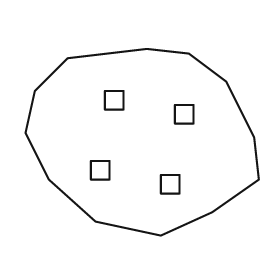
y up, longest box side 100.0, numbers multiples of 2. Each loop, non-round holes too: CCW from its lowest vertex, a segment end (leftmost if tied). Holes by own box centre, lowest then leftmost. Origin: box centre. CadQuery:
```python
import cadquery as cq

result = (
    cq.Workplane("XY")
    .moveTo(8.0, -40.0)
    .lineTo(30.0, -30.0)
    .lineTo(50.0, -16.0)
    .lineTo(48.0, 2.0)
    .lineTo(36.0, 26.0)
    .lineTo(20.0, 38.0)
    .lineTo(2.0, 40.0)
    .lineTo(-32.0, 36.0)
    .lineTo(-46.0, 22.0)
    .lineTo(-50.0, 4.0)
    .lineTo(-40.0, -16.0)
    .lineTo(-20.0, -34.0)
    .close()
    .moveTo(8.0, -22.0)
    .lineTo(16.0, -22.0)
    .lineTo(16.0, -14.0)
    .lineTo(8.0, -14.0)
    .close()
    .moveTo(-22.0, -16.0)
    .lineTo(-14.0, -16.0)
    .lineTo(-14.0, -8.0)
    .lineTo(-22.0, -8.0)
    .close()
    .moveTo(14.0, 8.0)
    .lineTo(22.0, 8.0)
    .lineTo(22.0, 16.0)
    .lineTo(14.0, 16.0)
    .close()
    .moveTo(-16.0, 14.0)
    .lineTo(-8.0, 14.0)
    .lineTo(-8.0, 22.0)
    .lineTo(-16.0, 22.0)
    .close()
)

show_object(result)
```